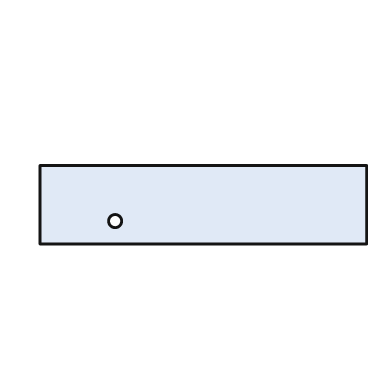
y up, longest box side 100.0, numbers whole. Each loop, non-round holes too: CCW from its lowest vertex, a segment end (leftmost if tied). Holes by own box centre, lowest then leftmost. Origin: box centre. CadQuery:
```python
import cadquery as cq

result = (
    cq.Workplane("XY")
    .moveTo(-50.0, -12.0)
    .lineTo(50.0, -12.0)
    .lineTo(50.0, 12.0)
    .lineTo(-50.0, 12.0)
    .close()
    .moveTo(-27.0, -5.0)
    .circle(2.0)
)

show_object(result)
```